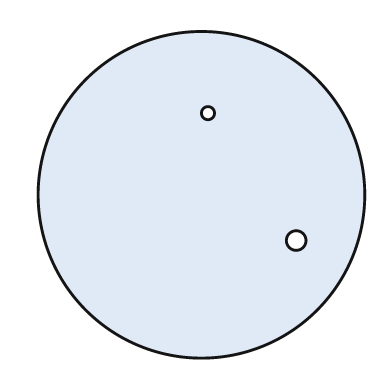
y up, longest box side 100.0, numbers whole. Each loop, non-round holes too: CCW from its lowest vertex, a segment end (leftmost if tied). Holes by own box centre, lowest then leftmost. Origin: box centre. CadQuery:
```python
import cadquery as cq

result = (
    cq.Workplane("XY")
    .moveTo(0.0, 0.0)
    .circle(50.0)
    .moveTo(29.0, -14.0)
    .circle(3.0)
    .moveTo(2.0, 25.0)
    .circle(2.0)
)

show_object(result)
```